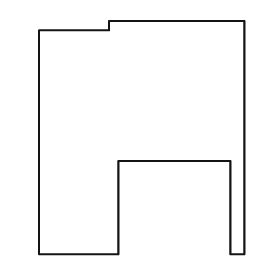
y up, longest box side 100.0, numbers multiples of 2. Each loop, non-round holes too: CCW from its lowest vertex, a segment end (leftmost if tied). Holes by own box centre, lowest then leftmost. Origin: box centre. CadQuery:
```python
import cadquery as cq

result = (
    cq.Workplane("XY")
    .moveTo(-44.0, -50.0)
    .lineTo(-10.0, -50.0)
    .lineTo(-10.0, -10.0)
    .lineTo(38.0, -10.0)
    .lineTo(38.0, -50.0)
    .lineTo(44.0, -50.0)
    .lineTo(44.0, 50.0)
    .lineTo(-14.0, 50.0)
    .lineTo(-14.0, 46.0)
    .lineTo(-44.0, 46.0)
    .close()
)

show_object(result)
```